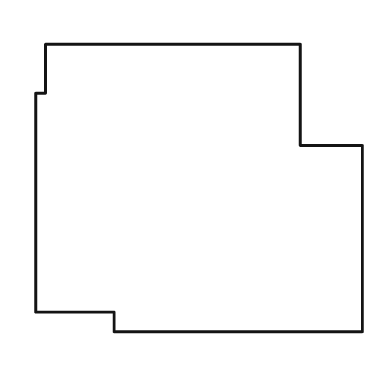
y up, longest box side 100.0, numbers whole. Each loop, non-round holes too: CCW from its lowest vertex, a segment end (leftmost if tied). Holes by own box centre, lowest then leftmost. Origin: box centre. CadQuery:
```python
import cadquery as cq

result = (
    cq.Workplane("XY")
    .moveTo(-26.0, -44.0)
    .lineTo(50.0, -44.0)
    .lineTo(50.0, 13.0)
    .lineTo(31.0, 13.0)
    .lineTo(31.0, 44.0)
    .lineTo(-47.0, 44.0)
    .lineTo(-47.0, 29.0)
    .lineTo(-50.0, 29.0)
    .lineTo(-50.0, -38.0)
    .lineTo(-26.0, -38.0)
    .close()
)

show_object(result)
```